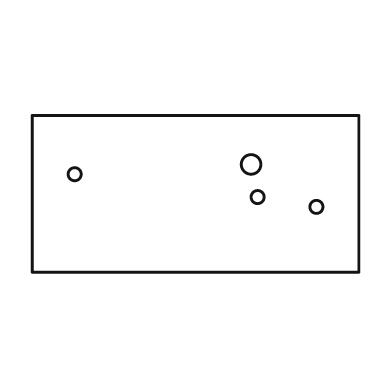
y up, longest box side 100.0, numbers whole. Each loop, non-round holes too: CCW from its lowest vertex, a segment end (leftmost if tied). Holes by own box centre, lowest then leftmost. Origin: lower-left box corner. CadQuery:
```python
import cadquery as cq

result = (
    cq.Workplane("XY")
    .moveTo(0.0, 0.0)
    .lineTo(100.0, 0.0)
    .lineTo(100.0, 48.0)
    .lineTo(0.0, 48.0)
    .close()
    .moveTo(87.0, 20.0)
    .circle(2.0)
    .moveTo(69.0, 23.0)
    .circle(2.0)
    .moveTo(13.0, 30.0)
    .circle(2.0)
    .moveTo(67.0, 33.0)
    .circle(3.0)
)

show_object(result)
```